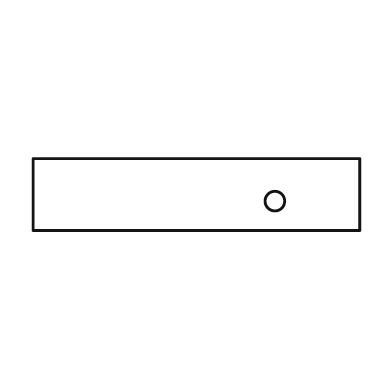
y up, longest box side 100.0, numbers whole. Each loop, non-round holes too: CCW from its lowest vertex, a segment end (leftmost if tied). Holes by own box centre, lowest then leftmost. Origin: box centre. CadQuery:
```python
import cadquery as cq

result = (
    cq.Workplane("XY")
    .moveTo(-50.0, -11.0)
    .lineTo(50.0, -11.0)
    .lineTo(50.0, 11.0)
    .lineTo(-50.0, 11.0)
    .close()
    .moveTo(24.0, -2.0)
    .circle(3.0)
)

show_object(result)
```